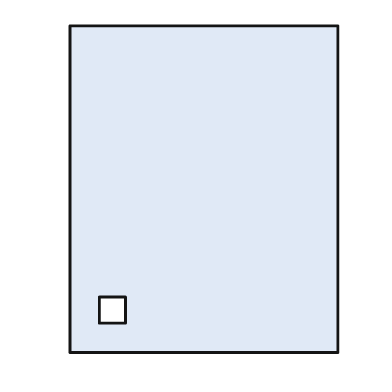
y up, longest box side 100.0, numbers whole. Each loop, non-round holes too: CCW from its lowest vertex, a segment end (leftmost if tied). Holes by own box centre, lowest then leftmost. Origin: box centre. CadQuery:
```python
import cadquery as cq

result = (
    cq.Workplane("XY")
    .moveTo(-41.0, -50.0)
    .lineTo(41.0, -50.0)
    .lineTo(41.0, 50.0)
    .lineTo(-41.0, 50.0)
    .close()
    .moveTo(-32.0, -41.0)
    .lineTo(-24.0, -41.0)
    .lineTo(-24.0, -33.0)
    .lineTo(-32.0, -33.0)
    .close()
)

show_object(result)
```